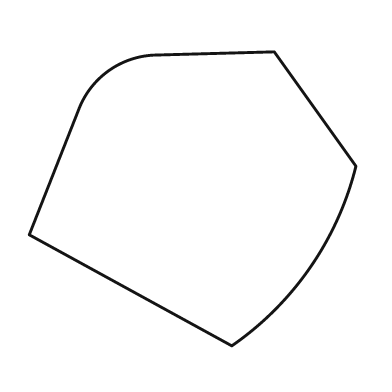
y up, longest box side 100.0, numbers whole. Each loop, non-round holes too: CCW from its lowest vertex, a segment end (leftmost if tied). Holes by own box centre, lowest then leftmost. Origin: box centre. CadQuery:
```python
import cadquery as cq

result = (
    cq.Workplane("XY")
    .moveTo(12.0, -45.0)
    .threePointArc((36.0, -21.0), (50.0, 10.0))
    .lineTo(25.0, 45.0)
    .lineTo(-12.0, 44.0)
    .threePointArc((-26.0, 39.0), (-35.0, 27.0))
    .lineTo(-50.0, -11.0)
    .close()
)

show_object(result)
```